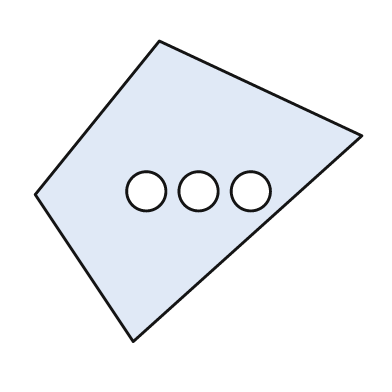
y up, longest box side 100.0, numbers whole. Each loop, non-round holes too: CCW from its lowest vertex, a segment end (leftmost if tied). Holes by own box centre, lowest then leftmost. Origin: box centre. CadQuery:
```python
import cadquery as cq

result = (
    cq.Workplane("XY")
    .moveTo(-20.0, -46.0)
    .lineTo(50.0, 17.0)
    .lineTo(-12.0, 46.0)
    .lineTo(-50.0, -1.0)
    .close()
    .moveTo(-16.0, 0.0)
    .circle(6.0)
    .moveTo(0.0, 0.0)
    .circle(6.0)
    .moveTo(16.0, 0.0)
    .circle(6.0)
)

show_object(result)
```